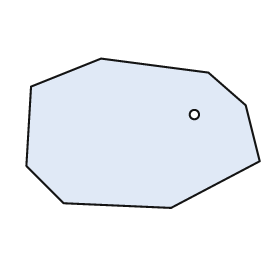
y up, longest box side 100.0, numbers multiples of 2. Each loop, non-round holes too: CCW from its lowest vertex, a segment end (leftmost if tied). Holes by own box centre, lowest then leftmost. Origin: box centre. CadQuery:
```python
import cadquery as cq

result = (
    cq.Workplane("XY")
    .moveTo(12.0, -32.0)
    .lineTo(50.0, -12.0)
    .lineTo(44.0, 12.0)
    .lineTo(28.0, 26.0)
    .lineTo(-18.0, 32.0)
    .lineTo(-48.0, 20.0)
    .lineTo(-50.0, -14.0)
    .lineTo(-34.0, -30.0)
    .close()
    .moveTo(22.0, 8.0)
    .circle(2.0)
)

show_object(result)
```